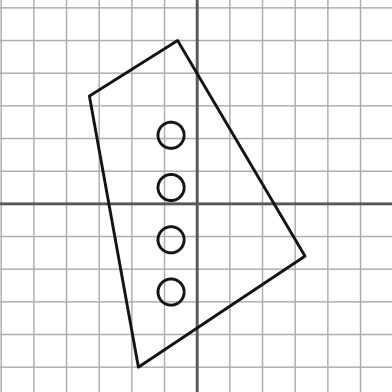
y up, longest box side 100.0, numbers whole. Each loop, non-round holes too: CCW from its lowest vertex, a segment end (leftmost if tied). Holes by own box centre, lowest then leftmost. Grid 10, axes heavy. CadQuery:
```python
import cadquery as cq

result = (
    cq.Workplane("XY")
    .moveTo(-18.0, -50.0)
    .lineTo(33.0, -16.0)
    .lineTo(-6.0, 50.0)
    .lineTo(-33.0, 33.0)
    .close()
    .moveTo(-8.0, -27.0)
    .circle(4.0)
    .moveTo(-8.0, -11.0)
    .circle(4.0)
    .moveTo(-8.0, 5.0)
    .circle(4.0)
    .moveTo(-8.0, 21.0)
    .circle(4.0)
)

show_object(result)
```